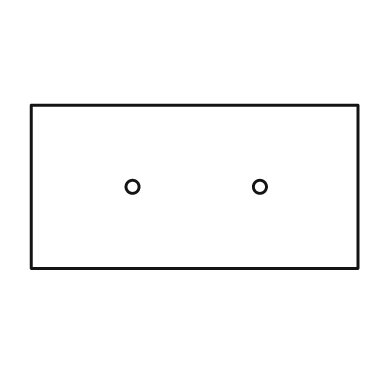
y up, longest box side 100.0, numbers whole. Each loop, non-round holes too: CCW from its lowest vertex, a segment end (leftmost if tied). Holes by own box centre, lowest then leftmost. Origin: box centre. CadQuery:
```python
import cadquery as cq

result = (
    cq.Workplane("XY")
    .moveTo(-50.0, -25.0)
    .lineTo(50.0, -25.0)
    .lineTo(50.0, 25.0)
    .lineTo(-50.0, 25.0)
    .close()
    .moveTo(-19.0, 0.0)
    .circle(2.0)
    .moveTo(20.0, 0.0)
    .circle(2.0)
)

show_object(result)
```